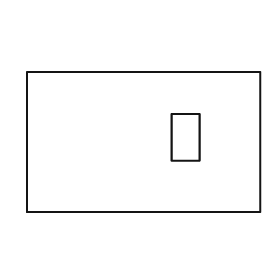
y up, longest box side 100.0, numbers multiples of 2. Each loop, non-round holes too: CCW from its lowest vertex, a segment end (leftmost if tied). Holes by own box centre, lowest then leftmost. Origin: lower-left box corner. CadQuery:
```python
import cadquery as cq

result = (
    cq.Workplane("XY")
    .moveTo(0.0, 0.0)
    .lineTo(100.0, 0.0)
    .lineTo(100.0, 60.0)
    .lineTo(0.0, 60.0)
    .close()
    .moveTo(62.0, 22.0)
    .lineTo(74.0, 22.0)
    .lineTo(74.0, 42.0)
    .lineTo(62.0, 42.0)
    .close()
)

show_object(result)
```